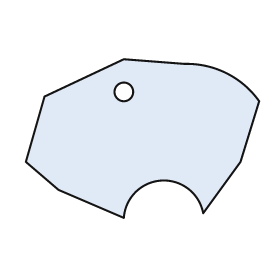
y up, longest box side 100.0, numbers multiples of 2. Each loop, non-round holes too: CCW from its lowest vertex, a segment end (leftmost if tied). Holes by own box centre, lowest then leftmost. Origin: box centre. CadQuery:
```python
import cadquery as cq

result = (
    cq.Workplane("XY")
    .moveTo(-8.0, -34.0)
    .threePointArc((8.0, -18.0), (26.0, -32.0))
    .lineTo(42.0, -10.0)
    .lineTo(50.0, 16.0)
    .threePointArc((36.0, 28.0), (18.0, 32.0))
    .lineTo(-8.0, 34.0)
    .lineTo(-42.0, 18.0)
    .lineTo(-50.0, -10.0)
    .lineTo(-36.0, -22.0)
    .close()
    .moveTo(-8.0, 20.0)
    .circle(4.0)
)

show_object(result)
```